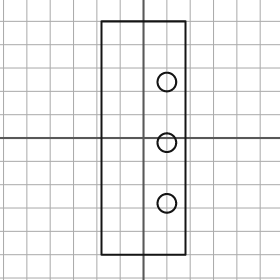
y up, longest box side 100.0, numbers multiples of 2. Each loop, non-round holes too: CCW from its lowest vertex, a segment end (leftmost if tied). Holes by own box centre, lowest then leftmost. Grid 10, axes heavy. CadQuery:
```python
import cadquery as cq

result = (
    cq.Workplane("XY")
    .moveTo(-18.0, -50.0)
    .lineTo(18.0, -50.0)
    .lineTo(18.0, 50.0)
    .lineTo(-18.0, 50.0)
    .close()
    .moveTo(10.0, -28.0)
    .circle(4.0)
    .moveTo(10.0, -2.0)
    .circle(4.0)
    .moveTo(10.0, 24.0)
    .circle(4.0)
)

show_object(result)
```